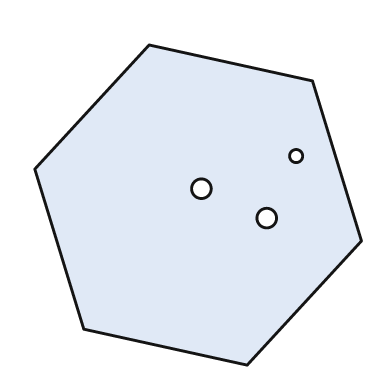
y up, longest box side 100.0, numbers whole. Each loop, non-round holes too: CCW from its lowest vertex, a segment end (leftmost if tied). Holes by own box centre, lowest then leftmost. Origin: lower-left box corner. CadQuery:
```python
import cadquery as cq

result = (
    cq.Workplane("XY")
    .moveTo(65.0, 0.0)
    .lineTo(100.0, 38.0)
    .lineTo(85.0, 87.0)
    .lineTo(35.0, 98.0)
    .lineTo(0.0, 60.0)
    .lineTo(15.0, 11.0)
    .close()
    .moveTo(71.0, 45.0)
    .circle(3.0)
    .moveTo(51.0, 54.0)
    .circle(3.0)
    .moveTo(80.0, 64.0)
    .circle(2.0)
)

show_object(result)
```